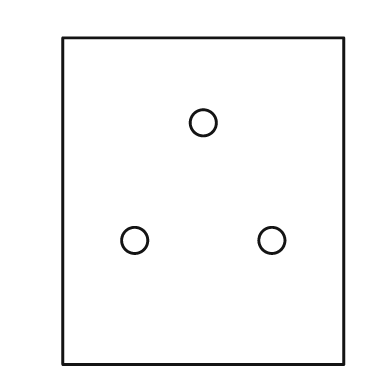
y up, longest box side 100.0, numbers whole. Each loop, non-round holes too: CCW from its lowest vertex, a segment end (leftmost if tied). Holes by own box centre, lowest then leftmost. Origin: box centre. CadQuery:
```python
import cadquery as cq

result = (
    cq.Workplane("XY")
    .moveTo(-43.0, -50.0)
    .lineTo(43.0, -50.0)
    .lineTo(43.0, 50.0)
    .lineTo(-43.0, 50.0)
    .close()
    .moveTo(-21.0, -12.0)
    .circle(4.0)
    .moveTo(21.0, -12.0)
    .circle(4.0)
    .moveTo(0.0, 24.0)
    .circle(4.0)
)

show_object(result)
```